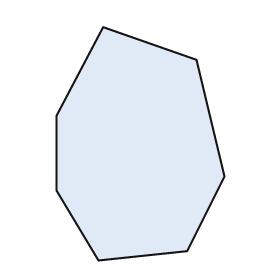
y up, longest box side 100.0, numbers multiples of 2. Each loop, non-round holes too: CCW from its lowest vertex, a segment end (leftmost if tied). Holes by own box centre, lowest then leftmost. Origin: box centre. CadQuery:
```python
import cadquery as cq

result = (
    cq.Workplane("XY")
    .moveTo(-18.0, -50.0)
    .lineTo(20.0, -46.0)
    .lineTo(36.0, -14.0)
    .lineTo(24.0, 36.0)
    .lineTo(-16.0, 50.0)
    .lineTo(-36.0, 12.0)
    .lineTo(-36.0, -20.0)
    .close()
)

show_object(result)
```